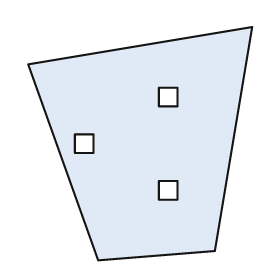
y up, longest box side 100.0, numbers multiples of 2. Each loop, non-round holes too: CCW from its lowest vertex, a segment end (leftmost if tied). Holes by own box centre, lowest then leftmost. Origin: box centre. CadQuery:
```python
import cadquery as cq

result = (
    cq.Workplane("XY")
    .moveTo(-18.0, -50.0)
    .lineTo(32.0, -46.0)
    .lineTo(48.0, 50.0)
    .lineTo(-48.0, 34.0)
    .close()
    .moveTo(8.0, -24.0)
    .lineTo(16.0, -24.0)
    .lineTo(16.0, -16.0)
    .lineTo(8.0, -16.0)
    .close()
    .moveTo(-28.0, -4.0)
    .lineTo(-20.0, -4.0)
    .lineTo(-20.0, 4.0)
    .lineTo(-28.0, 4.0)
    .close()
    .moveTo(8.0, 16.0)
    .lineTo(16.0, 16.0)
    .lineTo(16.0, 24.0)
    .lineTo(8.0, 24.0)
    .close()
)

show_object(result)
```